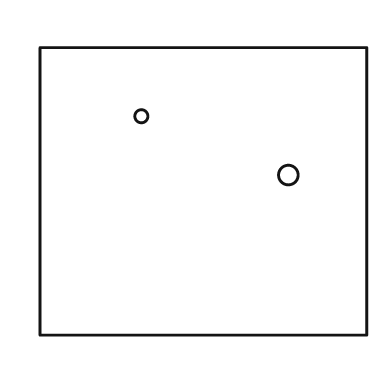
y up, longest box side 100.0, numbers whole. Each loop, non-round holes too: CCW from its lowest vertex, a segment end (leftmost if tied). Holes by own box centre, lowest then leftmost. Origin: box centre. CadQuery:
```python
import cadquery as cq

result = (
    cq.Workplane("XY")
    .moveTo(-50.0, -44.0)
    .lineTo(50.0, -44.0)
    .lineTo(50.0, 44.0)
    .lineTo(-50.0, 44.0)
    .close()
    .moveTo(26.0, 5.0)
    .circle(3.0)
    .moveTo(-19.0, 23.0)
    .circle(2.0)
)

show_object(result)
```